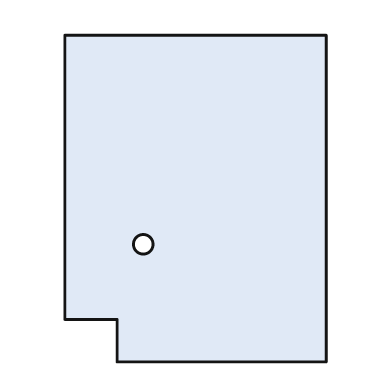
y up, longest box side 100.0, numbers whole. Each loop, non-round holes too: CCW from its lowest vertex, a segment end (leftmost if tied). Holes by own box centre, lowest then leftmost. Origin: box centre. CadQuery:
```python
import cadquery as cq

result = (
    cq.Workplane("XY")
    .moveTo(-24.0, -50.0)
    .lineTo(40.0, -50.0)
    .lineTo(40.0, 50.0)
    .lineTo(-40.0, 50.0)
    .lineTo(-40.0, -37.0)
    .lineTo(-24.0, -37.0)
    .close()
    .moveTo(-16.0, -14.0)
    .circle(3.0)
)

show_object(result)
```